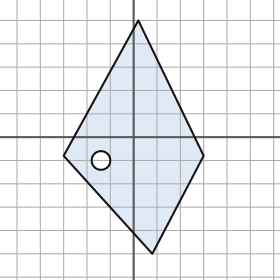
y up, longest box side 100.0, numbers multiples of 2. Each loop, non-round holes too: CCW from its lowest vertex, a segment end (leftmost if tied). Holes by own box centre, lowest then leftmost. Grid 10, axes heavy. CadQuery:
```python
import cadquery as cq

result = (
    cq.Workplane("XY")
    .moveTo(8.0, -50.0)
    .lineTo(30.0, -8.0)
    .lineTo(2.0, 50.0)
    .lineTo(-30.0, -8.0)
    .close()
    .moveTo(-14.0, -10.0)
    .circle(4.0)
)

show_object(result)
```